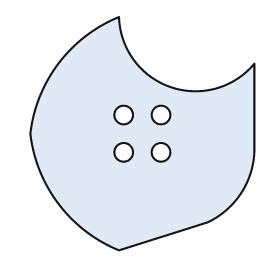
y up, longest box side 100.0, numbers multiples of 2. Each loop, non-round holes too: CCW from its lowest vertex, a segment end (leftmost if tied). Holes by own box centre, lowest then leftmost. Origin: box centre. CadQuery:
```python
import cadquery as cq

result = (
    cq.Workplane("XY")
    .moveTo(-10.0, -50.0)
    .lineTo(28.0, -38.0)
    .threePointArc((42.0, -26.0), (48.0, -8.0))
    .lineTo(48.0, 30.0)
    .threePointArc((12.0, 20.0), (-10.0, 50.0))
    .threePointArc((-36.0, 30.0), (-48.0, 0.0))
    .threePointArc((-36.0, -30.0), (-10.0, -50.0))
    .close()
    .moveTo(-8.0, -8.0)
    .circle(4.0)
    .moveTo(8.0, -8.0)
    .circle(4.0)
    .moveTo(-8.0, 8.0)
    .circle(4.0)
    .moveTo(8.0, 8.0)
    .circle(4.0)
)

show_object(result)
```